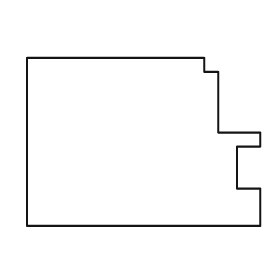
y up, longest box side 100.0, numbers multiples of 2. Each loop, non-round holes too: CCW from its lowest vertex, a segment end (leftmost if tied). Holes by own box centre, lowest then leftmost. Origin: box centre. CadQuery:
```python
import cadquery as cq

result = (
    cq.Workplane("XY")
    .moveTo(-50.0, -36.0)
    .lineTo(50.0, -36.0)
    .lineTo(50.0, -20.0)
    .lineTo(40.0, -20.0)
    .lineTo(40.0, -2.0)
    .lineTo(50.0, -2.0)
    .lineTo(50.0, 4.0)
    .lineTo(32.0, 4.0)
    .lineTo(32.0, 30.0)
    .lineTo(26.0, 30.0)
    .lineTo(26.0, 36.0)
    .lineTo(-50.0, 36.0)
    .close()
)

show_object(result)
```